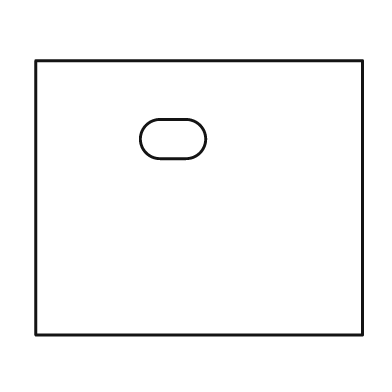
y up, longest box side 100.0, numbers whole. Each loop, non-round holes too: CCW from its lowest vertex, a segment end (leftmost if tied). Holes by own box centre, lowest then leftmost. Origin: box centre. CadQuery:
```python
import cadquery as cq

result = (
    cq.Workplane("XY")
    .moveTo(-50.0, -42.0)
    .lineTo(50.0, -42.0)
    .lineTo(50.0, 42.0)
    .lineTo(-50.0, 42.0)
    .close()
    .moveTo(-12.0, 12.0)
    .lineTo(-4.0, 12.0)
    .threePointArc((2.0, 18.0), (-4.0, 24.0))
    .lineTo(-12.0, 24.0)
    .threePointArc((-18.0, 18.0), (-12.0, 12.0))
    .close()
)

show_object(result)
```